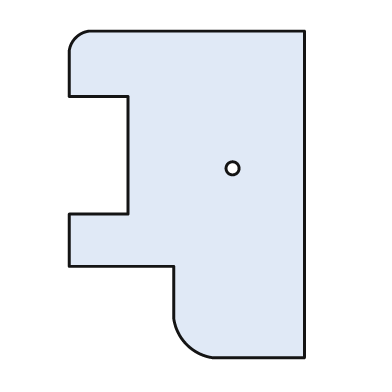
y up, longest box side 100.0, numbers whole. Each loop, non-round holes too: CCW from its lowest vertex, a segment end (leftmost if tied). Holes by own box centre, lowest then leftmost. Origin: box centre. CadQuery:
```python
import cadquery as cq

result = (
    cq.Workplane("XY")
    .moveTo(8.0, -50.0)
    .lineTo(36.0, -50.0)
    .lineTo(36.0, 50.0)
    .lineTo(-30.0, 50.0)
    .threePointArc((-34.0, 48.0), (-36.0, 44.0))
    .lineTo(-36.0, 30.0)
    .lineTo(-18.0, 30.0)
    .lineTo(-18.0, -6.0)
    .lineTo(-36.0, -6.0)
    .lineTo(-36.0, -22.0)
    .lineTo(-4.0, -22.0)
    .lineTo(-4.0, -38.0)
    .threePointArc((0.0, -46.0), (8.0, -50.0))
    .close()
    .moveTo(14.0, 8.0)
    .circle(2.0)
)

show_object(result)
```